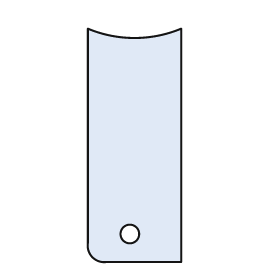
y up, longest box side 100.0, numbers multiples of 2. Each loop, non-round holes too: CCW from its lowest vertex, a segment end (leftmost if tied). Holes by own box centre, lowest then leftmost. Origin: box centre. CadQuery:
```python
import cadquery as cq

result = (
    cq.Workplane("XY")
    .moveTo(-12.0, -50.0)
    .lineTo(20.0, -50.0)
    .lineTo(20.0, 50.0)
    .threePointArc((0.0, 46.0), (-20.0, 50.0))
    .lineTo(-20.0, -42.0)
    .threePointArc((-18.0, -48.0), (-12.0, -50.0))
    .close()
    .moveTo(-2.0, -38.0)
    .circle(4.0)
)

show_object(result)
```